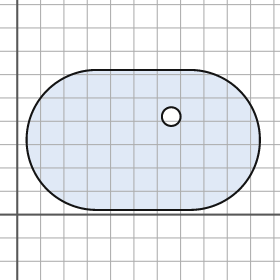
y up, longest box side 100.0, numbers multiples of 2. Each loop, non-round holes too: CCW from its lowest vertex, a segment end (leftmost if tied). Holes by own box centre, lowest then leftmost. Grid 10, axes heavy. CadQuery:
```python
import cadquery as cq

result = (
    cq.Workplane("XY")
    .moveTo(34.0, 2.0)
    .lineTo(74.0, 2.0)
    .threePointArc((104.0, 32.0), (74.0, 62.0))
    .lineTo(34.0, 62.0)
    .threePointArc((4.0, 32.0), (34.0, 2.0))
    .close()
    .moveTo(66.0, 42.0)
    .circle(4.0)
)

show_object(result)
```